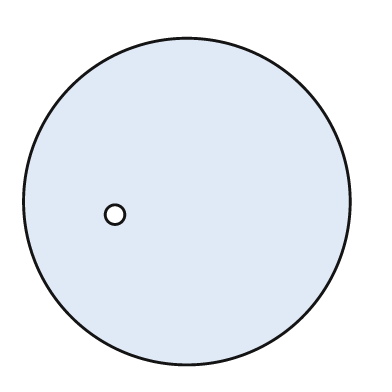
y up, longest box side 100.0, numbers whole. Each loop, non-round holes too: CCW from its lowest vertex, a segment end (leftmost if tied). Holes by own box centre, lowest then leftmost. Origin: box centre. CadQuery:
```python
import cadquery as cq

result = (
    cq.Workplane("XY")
    .moveTo(0.0, 0.0)
    .circle(50.0)
    .moveTo(-22.0, -4.0)
    .circle(3.0)
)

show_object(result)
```